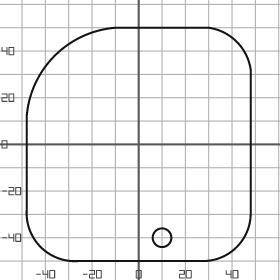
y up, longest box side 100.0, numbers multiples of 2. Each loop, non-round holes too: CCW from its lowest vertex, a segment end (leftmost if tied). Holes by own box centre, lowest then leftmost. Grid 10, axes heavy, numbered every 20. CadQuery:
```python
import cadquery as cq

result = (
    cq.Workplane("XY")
    .moveTo(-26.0, -50.0)
    .lineTo(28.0, -50.0)
    .threePointArc((42.0, -44.0), (48.0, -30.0))
    .lineTo(48.0, 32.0)
    .threePointArc((42.0, 44.0), (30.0, 50.0))
    .lineTo(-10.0, 50.0)
    .threePointArc((-36.0, 38.0), (-48.0, 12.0))
    .lineTo(-48.0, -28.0)
    .threePointArc((-42.0, -44.0), (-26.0, -50.0))
    .close()
    .moveTo(10.0, -40.0)
    .circle(4.0)
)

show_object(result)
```